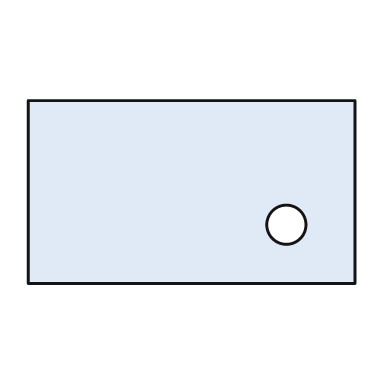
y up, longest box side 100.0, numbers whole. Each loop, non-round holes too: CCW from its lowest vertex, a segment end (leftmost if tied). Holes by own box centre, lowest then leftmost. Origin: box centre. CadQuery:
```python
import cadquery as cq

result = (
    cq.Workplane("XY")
    .moveTo(-50.0, -28.0)
    .lineTo(50.0, -28.0)
    .lineTo(50.0, 28.0)
    .lineTo(-50.0, 28.0)
    .close()
    .moveTo(29.0, -10.0)
    .circle(6.0)
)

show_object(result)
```